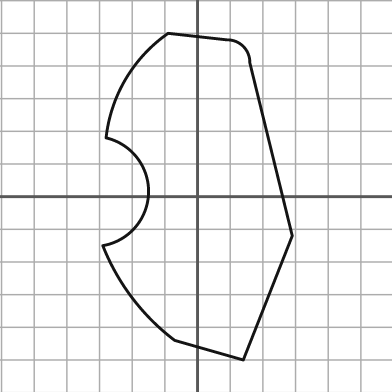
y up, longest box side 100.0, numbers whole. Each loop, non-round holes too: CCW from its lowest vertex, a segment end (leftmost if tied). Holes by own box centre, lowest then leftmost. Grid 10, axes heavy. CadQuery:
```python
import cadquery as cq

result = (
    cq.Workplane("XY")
    .moveTo(14.0, -50.0)
    .lineTo(29.0, -12.0)
    .lineTo(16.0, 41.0)
    .threePointArc((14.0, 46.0), (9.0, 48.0))
    .lineTo(-9.0, 50.0)
    .threePointArc((-22.0, 36.0), (-28.0, 18.0))
    .threePointArc((-15.0, 1.0), (-29.0, -15.0))
    .threePointArc((-20.0, -31.0), (-7.0, -44.0))
    .close()
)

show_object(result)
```